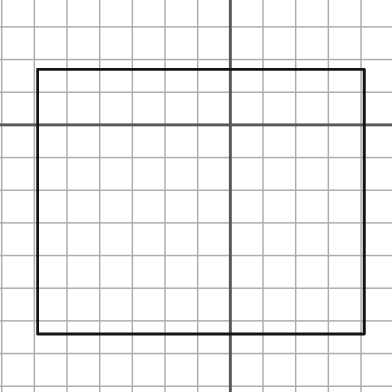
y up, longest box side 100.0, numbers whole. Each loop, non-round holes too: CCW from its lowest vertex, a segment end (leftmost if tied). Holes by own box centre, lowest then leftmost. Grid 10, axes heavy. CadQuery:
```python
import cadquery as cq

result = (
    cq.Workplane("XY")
    .moveTo(-59.0, -64.0)
    .lineTo(41.0, -64.0)
    .lineTo(41.0, 17.0)
    .lineTo(-59.0, 17.0)
    .close()
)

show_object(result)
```